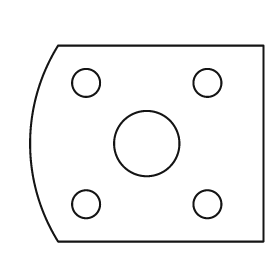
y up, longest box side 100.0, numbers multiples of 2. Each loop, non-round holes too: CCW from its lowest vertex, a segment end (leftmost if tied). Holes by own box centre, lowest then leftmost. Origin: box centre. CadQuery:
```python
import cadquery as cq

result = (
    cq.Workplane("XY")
    .moveTo(-38.0, -42.0)
    .lineTo(50.0, -42.0)
    .lineTo(50.0, 42.0)
    .lineTo(-38.0, 42.0)
    .threePointArc((-50.0, 0.0), (-38.0, -42.0))
    .close()
    .moveTo(-26.0, -26.0)
    .circle(6.0)
    .moveTo(26.0, -26.0)
    .circle(6.0)
    .moveTo(0.0, 0.0)
    .circle(14.0)
    .moveTo(-26.0, 26.0)
    .circle(6.0)
    .moveTo(26.0, 26.0)
    .circle(6.0)
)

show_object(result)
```